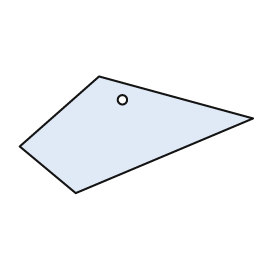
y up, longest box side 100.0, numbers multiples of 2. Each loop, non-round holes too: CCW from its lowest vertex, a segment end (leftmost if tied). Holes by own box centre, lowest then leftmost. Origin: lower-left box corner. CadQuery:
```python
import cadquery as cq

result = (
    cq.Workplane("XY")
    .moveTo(24.0, 0.0)
    .lineTo(100.0, 32.0)
    .lineTo(34.0, 50.0)
    .lineTo(0.0, 20.0)
    .close()
    .moveTo(44.0, 40.0)
    .circle(2.0)
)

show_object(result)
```